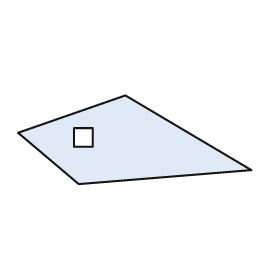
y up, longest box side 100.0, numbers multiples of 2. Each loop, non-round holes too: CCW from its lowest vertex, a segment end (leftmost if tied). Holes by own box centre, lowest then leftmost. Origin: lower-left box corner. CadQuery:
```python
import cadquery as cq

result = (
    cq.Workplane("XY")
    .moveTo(26.0, 0.0)
    .lineTo(100.0, 6.0)
    .lineTo(46.0, 38.0)
    .lineTo(0.0, 22.0)
    .close()
    .moveTo(24.0, 16.0)
    .lineTo(32.0, 16.0)
    .lineTo(32.0, 24.0)
    .lineTo(24.0, 24.0)
    .close()
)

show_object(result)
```